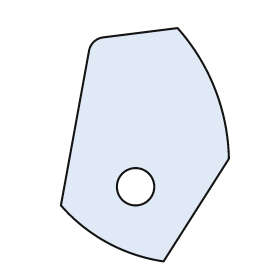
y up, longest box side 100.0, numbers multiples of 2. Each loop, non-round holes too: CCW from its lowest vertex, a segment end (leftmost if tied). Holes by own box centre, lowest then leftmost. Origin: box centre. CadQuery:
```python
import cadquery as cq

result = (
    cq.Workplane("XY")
    .moveTo(8.0, -50.0)
    .lineTo(36.0, -6.0)
    .threePointArc((30.0, 24.0), (14.0, 50.0))
    .lineTo(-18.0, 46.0)
    .threePointArc((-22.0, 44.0), (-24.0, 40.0))
    .lineTo(-36.0, -26.0)
    .threePointArc((-16.0, -42.0), (8.0, -50.0))
    .close()
    .moveTo(-4.0, -18.0)
    .circle(8.0)
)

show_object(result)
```